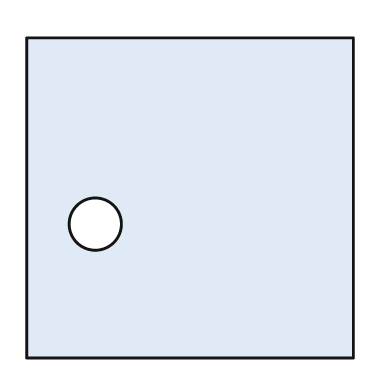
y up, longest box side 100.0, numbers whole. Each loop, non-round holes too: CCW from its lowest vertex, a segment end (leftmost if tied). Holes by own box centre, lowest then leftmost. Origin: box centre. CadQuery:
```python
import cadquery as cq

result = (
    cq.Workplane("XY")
    .moveTo(-50.0, -49.0)
    .lineTo(50.0, -49.0)
    .lineTo(50.0, 49.0)
    .lineTo(-50.0, 49.0)
    .close()
    .moveTo(-29.0, -8.0)
    .circle(8.0)
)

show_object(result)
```